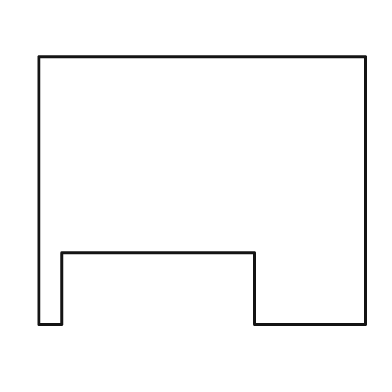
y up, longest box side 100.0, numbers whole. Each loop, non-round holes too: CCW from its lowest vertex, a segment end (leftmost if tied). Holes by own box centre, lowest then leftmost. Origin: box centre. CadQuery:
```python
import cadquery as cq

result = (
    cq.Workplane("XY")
    .moveTo(-50.0, -41.0)
    .lineTo(-43.0, -41.0)
    .lineTo(-43.0, -19.0)
    .lineTo(16.0, -19.0)
    .lineTo(16.0, -41.0)
    .lineTo(50.0, -41.0)
    .lineTo(50.0, 41.0)
    .lineTo(-50.0, 41.0)
    .close()
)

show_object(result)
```